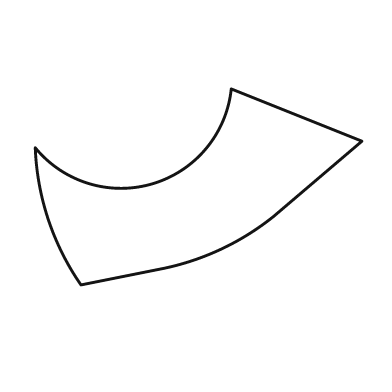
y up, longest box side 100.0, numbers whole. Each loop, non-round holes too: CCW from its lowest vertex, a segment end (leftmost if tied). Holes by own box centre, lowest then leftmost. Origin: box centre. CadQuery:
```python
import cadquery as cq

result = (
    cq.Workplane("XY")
    .moveTo(-36.0, -30.0)
    .lineTo(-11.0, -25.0)
    .threePointArc((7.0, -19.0), (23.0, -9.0))
    .lineTo(50.0, 14.0)
    .lineTo(10.0, 30.0)
    .threePointArc((-14.0, 1.0), (-50.0, 12.0))
    .threePointArc((-46.0, -10.0), (-36.0, -30.0))
    .close()
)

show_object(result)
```